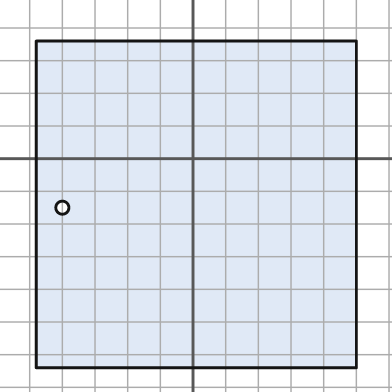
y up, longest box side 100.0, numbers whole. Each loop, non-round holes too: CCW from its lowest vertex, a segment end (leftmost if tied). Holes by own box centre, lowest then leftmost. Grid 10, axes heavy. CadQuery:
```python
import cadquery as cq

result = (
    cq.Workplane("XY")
    .moveTo(-48.0, -64.0)
    .lineTo(50.0, -64.0)
    .lineTo(50.0, 36.0)
    .lineTo(-48.0, 36.0)
    .close()
    .moveTo(-40.0, -15.0)
    .circle(2.0)
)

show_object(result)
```